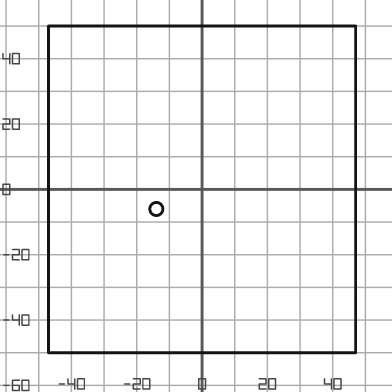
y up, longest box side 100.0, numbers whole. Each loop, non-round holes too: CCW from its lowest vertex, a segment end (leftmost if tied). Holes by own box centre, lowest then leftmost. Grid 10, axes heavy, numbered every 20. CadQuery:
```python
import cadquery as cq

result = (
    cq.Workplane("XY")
    .moveTo(-47.0, -50.0)
    .lineTo(47.0, -50.0)
    .lineTo(47.0, 50.0)
    .lineTo(-47.0, 50.0)
    .close()
    .moveTo(-14.0, -6.0)
    .circle(2.0)
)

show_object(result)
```